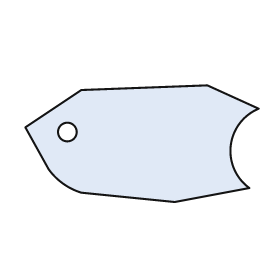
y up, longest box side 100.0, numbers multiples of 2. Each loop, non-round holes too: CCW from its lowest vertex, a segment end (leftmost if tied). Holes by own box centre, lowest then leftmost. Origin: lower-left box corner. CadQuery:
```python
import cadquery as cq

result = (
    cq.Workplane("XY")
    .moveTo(64.0, 0.0)
    .lineTo(96.0, 6.0)
    .threePointArc((88.0, 24.0), (100.0, 40.0))
    .lineTo(78.0, 50.0)
    .lineTo(24.0, 48.0)
    .lineTo(0.0, 32.0)
    .lineTo(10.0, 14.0)
    .threePointArc((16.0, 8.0), (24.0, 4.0))
    .close()
    .moveTo(18.0, 30.0)
    .circle(4.0)
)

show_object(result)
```